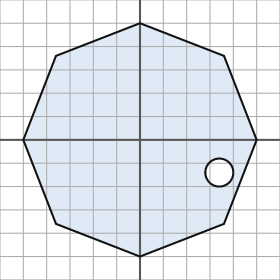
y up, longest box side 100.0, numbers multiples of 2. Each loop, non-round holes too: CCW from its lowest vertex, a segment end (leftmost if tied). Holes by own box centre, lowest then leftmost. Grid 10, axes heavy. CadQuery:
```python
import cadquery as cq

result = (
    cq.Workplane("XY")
    .moveTo(0.0, -50.0)
    .lineTo(36.0, -36.0)
    .lineTo(50.0, 0.0)
    .lineTo(36.0, 36.0)
    .lineTo(0.0, 50.0)
    .lineTo(-36.0, 36.0)
    .lineTo(-50.0, 0.0)
    .lineTo(-36.0, -36.0)
    .close()
    .moveTo(34.0, -14.0)
    .circle(6.0)
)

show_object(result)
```